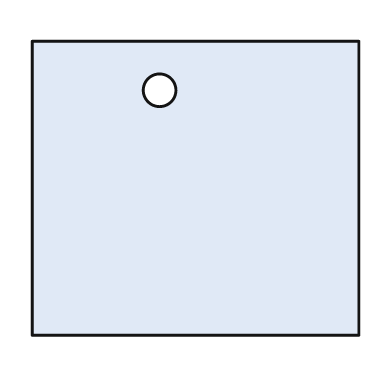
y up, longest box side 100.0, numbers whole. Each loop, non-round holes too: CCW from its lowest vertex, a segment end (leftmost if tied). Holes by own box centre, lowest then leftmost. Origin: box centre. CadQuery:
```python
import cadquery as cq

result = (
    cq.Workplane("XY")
    .moveTo(-50.0, -45.0)
    .lineTo(50.0, -45.0)
    .lineTo(50.0, 45.0)
    .lineTo(-50.0, 45.0)
    .close()
    .moveTo(-11.0, 30.0)
    .circle(5.0)
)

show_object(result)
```